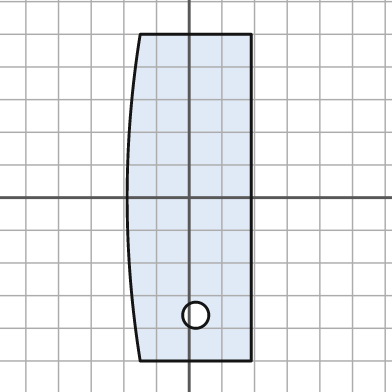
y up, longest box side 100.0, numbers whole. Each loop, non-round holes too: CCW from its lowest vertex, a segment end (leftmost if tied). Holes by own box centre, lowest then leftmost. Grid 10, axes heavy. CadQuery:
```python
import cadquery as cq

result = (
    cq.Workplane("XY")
    .moveTo(-15.0, -50.0)
    .lineTo(19.0, -50.0)
    .lineTo(19.0, 50.0)
    .lineTo(-15.0, 50.0)
    .threePointArc((-19.0, 0.0), (-15.0, -50.0))
    .close()
    .moveTo(2.0, -36.0)
    .circle(4.0)
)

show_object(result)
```